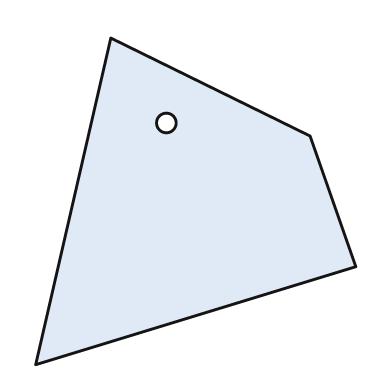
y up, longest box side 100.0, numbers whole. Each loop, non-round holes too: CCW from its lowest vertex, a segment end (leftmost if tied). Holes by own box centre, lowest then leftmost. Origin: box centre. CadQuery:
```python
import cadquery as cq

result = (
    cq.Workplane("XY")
    .moveTo(-49.0, -50.0)
    .lineTo(49.0, -20.0)
    .lineTo(35.0, 20.0)
    .lineTo(-26.0, 50.0)
    .close()
    .moveTo(-9.0, 24.0)
    .circle(3.0)
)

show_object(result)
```